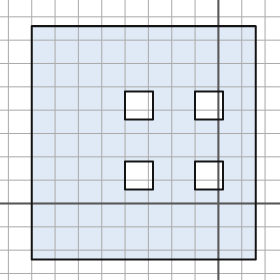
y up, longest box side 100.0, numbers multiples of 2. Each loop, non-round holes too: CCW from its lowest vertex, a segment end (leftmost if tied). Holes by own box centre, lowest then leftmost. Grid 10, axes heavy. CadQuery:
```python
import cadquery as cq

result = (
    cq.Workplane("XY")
    .moveTo(-80.0, -24.0)
    .lineTo(16.0, -24.0)
    .lineTo(16.0, 76.0)
    .lineTo(-80.0, 76.0)
    .close()
    .moveTo(-40.0, 6.0)
    .lineTo(-28.0, 6.0)
    .lineTo(-28.0, 18.0)
    .lineTo(-40.0, 18.0)
    .close()
    .moveTo(-10.0, 6.0)
    .lineTo(2.0, 6.0)
    .lineTo(2.0, 18.0)
    .lineTo(-10.0, 18.0)
    .close()
    .moveTo(-40.0, 36.0)
    .lineTo(-28.0, 36.0)
    .lineTo(-28.0, 48.0)
    .lineTo(-40.0, 48.0)
    .close()
    .moveTo(-10.0, 36.0)
    .lineTo(2.0, 36.0)
    .lineTo(2.0, 48.0)
    .lineTo(-10.0, 48.0)
    .close()
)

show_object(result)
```